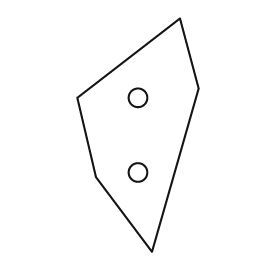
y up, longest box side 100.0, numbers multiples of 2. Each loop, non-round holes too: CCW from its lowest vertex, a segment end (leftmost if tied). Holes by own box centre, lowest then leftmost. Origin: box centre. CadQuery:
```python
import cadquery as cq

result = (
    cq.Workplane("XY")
    .moveTo(6.0, -50.0)
    .lineTo(26.0, 20.0)
    .lineTo(18.0, 50.0)
    .lineTo(-26.0, 16.0)
    .lineTo(-18.0, -18.0)
    .close()
    .moveTo(0.0, -16.0)
    .circle(4.0)
    .moveTo(0.0, 16.0)
    .circle(4.0)
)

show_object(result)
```